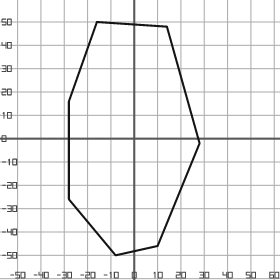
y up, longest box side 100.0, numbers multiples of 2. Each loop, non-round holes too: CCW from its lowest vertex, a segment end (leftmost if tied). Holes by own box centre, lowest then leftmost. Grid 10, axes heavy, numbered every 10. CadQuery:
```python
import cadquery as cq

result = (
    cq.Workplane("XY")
    .moveTo(-8.0, -50.0)
    .lineTo(10.0, -46.0)
    .lineTo(28.0, -2.0)
    .lineTo(14.0, 48.0)
    .lineTo(-16.0, 50.0)
    .lineTo(-28.0, 16.0)
    .lineTo(-28.0, -26.0)
    .close()
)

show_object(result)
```